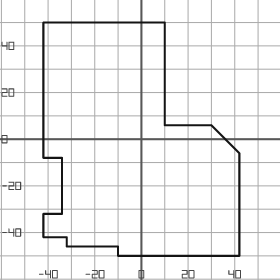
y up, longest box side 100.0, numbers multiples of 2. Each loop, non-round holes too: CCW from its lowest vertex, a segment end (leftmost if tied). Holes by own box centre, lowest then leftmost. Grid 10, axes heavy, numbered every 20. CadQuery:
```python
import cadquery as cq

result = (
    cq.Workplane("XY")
    .moveTo(-10.0, -50.0)
    .lineTo(42.0, -50.0)
    .lineTo(42.0, -6.0)
    .lineTo(30.0, 6.0)
    .lineTo(10.0, 6.0)
    .lineTo(10.0, 50.0)
    .lineTo(-42.0, 50.0)
    .lineTo(-42.0, -8.0)
    .lineTo(-34.0, -8.0)
    .lineTo(-34.0, -32.0)
    .lineTo(-42.0, -32.0)
    .lineTo(-42.0, -42.0)
    .lineTo(-32.0, -42.0)
    .lineTo(-32.0, -46.0)
    .lineTo(-10.0, -46.0)
    .close()
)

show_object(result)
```